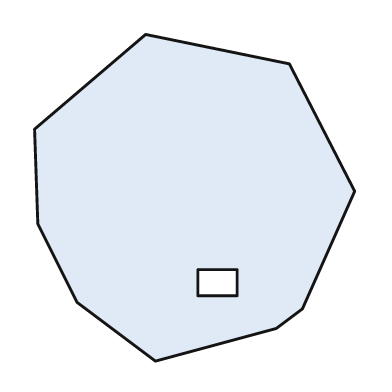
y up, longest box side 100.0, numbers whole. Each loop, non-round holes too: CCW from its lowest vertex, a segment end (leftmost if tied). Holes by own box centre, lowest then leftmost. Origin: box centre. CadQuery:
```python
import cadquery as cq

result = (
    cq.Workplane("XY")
    .moveTo(-12.0, -50.0)
    .lineTo(25.0, -40.0)
    .lineTo(33.0, -34.0)
    .lineTo(49.0, 2.0)
    .lineTo(29.0, 41.0)
    .lineTo(-15.0, 50.0)
    .lineTo(-49.0, 21.0)
    .lineTo(-48.0, -8.0)
    .lineTo(-36.0, -32.0)
    .close()
    .moveTo(1.0, -30.0)
    .lineTo(13.0, -30.0)
    .lineTo(13.0, -22.0)
    .lineTo(1.0, -22.0)
    .close()
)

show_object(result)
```